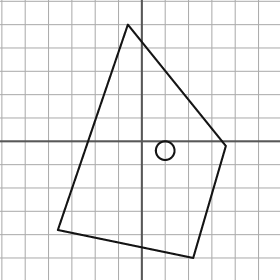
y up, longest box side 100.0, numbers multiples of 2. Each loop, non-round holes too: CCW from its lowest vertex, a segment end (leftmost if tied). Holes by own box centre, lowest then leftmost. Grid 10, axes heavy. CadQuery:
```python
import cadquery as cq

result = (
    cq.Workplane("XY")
    .moveTo(22.0, -50.0)
    .lineTo(36.0, -2.0)
    .lineTo(-6.0, 50.0)
    .lineTo(-36.0, -38.0)
    .close()
    .moveTo(10.0, -4.0)
    .circle(4.0)
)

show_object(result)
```